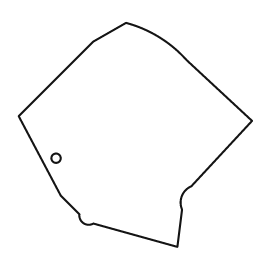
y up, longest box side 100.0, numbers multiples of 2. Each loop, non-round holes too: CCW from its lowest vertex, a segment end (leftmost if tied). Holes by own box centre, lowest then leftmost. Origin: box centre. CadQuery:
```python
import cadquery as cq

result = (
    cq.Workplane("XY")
    .moveTo(18.0, -48.0)
    .lineTo(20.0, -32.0)
    .threePointArc((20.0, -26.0), (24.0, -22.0))
    .lineTo(50.0, 6.0)
    .lineTo(22.0, 32.0)
    .threePointArc((10.0, 42.0), (-4.0, 48.0))
    .lineTo(-18.0, 40.0)
    .lineTo(-50.0, 8.0)
    .lineTo(-32.0, -26.0)
    .lineTo(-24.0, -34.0)
    .threePointArc((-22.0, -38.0), (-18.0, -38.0))
    .close()
    .moveTo(-34.0, -10.0)
    .circle(2.0)
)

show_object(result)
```